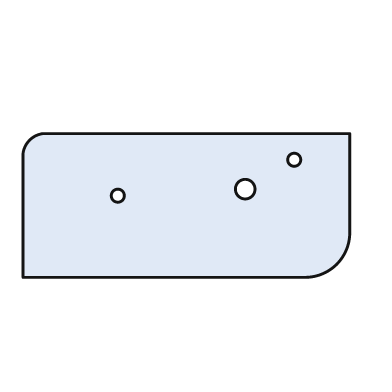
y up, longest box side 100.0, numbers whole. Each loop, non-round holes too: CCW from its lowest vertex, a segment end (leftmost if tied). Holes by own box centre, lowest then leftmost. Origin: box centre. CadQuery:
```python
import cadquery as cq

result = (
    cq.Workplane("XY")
    .moveTo(-50.0, -22.0)
    .lineTo(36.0, -22.0)
    .threePointArc((46.0, -18.0), (50.0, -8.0))
    .lineTo(50.0, 22.0)
    .lineTo(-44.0, 22.0)
    .threePointArc((-48.0, 20.0), (-50.0, 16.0))
    .close()
    .moveTo(-21.0, 3.0)
    .circle(2.0)
    .moveTo(18.0, 5.0)
    .circle(3.0)
    .moveTo(33.0, 14.0)
    .circle(2.0)
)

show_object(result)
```